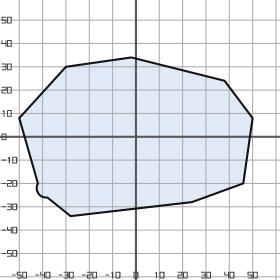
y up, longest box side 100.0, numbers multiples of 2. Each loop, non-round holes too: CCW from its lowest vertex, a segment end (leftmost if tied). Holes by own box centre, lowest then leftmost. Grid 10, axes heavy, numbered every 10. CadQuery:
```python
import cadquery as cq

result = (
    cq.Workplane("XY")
    .moveTo(-28.0, -34.0)
    .lineTo(24.0, -28.0)
    .lineTo(46.0, -20.0)
    .lineTo(50.0, 8.0)
    .lineTo(38.0, 24.0)
    .lineTo(-2.0, 34.0)
    .lineTo(-30.0, 30.0)
    .lineTo(-50.0, 8.0)
    .lineTo(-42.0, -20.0)
    .threePointArc((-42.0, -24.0), (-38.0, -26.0))
    .close()
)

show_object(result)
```